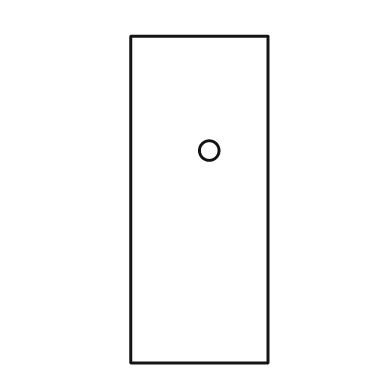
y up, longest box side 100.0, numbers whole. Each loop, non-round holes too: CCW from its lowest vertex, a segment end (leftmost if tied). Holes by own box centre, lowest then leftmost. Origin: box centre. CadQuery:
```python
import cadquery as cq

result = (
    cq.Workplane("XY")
    .moveTo(-21.0, -50.0)
    .lineTo(21.0, -50.0)
    .lineTo(21.0, 50.0)
    .lineTo(-21.0, 50.0)
    .close()
    .moveTo(3.0, 15.0)
    .circle(3.0)
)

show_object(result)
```